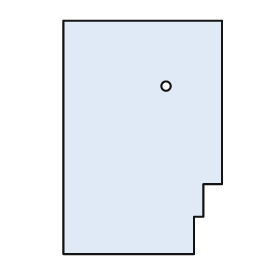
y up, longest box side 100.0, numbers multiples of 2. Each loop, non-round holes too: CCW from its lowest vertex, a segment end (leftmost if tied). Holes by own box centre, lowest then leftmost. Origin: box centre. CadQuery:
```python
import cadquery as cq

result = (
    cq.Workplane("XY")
    .moveTo(-34.0, -50.0)
    .lineTo(22.0, -50.0)
    .lineTo(22.0, -34.0)
    .lineTo(26.0, -34.0)
    .lineTo(26.0, -20.0)
    .lineTo(34.0, -20.0)
    .lineTo(34.0, 50.0)
    .lineTo(-34.0, 50.0)
    .close()
    .moveTo(10.0, 22.0)
    .circle(2.0)
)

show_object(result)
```